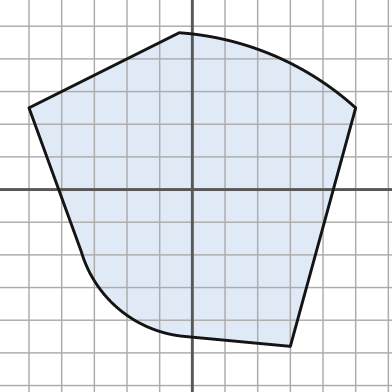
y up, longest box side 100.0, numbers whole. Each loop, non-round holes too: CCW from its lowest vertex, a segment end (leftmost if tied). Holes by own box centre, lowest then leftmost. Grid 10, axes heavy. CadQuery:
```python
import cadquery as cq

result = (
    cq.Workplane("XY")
    .moveTo(30.0, -48.0)
    .lineTo(50.0, 25.0)
    .threePointArc((25.0, 41.0), (-4.0, 48.0))
    .lineTo(-50.0, 25.0)
    .lineTo(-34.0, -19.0)
    .threePointArc((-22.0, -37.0), (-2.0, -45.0))
    .close()
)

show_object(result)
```